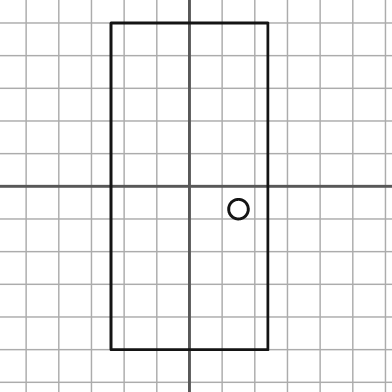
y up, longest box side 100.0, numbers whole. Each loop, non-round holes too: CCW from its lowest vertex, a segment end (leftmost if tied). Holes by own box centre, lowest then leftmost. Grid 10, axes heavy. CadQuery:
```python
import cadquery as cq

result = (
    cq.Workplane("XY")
    .moveTo(-24.0, -50.0)
    .lineTo(24.0, -50.0)
    .lineTo(24.0, 50.0)
    .lineTo(-24.0, 50.0)
    .close()
    .moveTo(15.0, -7.0)
    .circle(3.0)
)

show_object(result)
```